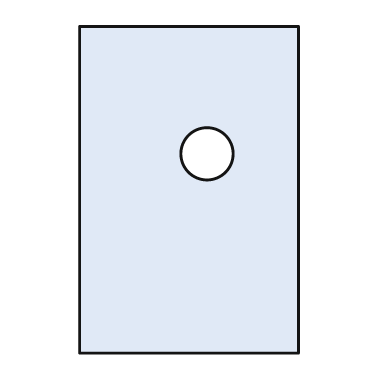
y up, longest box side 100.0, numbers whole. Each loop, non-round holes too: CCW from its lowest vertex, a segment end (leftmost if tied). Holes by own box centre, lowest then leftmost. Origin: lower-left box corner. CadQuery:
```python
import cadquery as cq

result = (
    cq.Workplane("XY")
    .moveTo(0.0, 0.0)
    .lineTo(67.0, 0.0)
    .lineTo(67.0, 100.0)
    .lineTo(0.0, 100.0)
    .close()
    .moveTo(39.0, 61.0)
    .circle(8.0)
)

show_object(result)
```